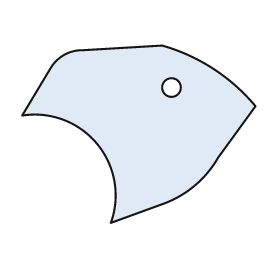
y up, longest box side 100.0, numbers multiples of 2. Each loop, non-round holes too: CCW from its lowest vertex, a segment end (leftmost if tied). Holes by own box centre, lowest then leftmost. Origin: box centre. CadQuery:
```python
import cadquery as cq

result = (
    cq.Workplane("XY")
    .moveTo(-12.0, -38.0)
    .lineTo(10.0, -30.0)
    .threePointArc((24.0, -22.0), (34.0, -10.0))
    .lineTo(50.0, 12.0)
    .threePointArc((32.0, 28.0), (10.0, 38.0))
    .lineTo(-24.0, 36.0)
    .threePointArc((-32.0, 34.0), (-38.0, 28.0))
    .lineTo(-50.0, 8.0)
    .threePointArc((-18.0, -4.0), (-12.0, -38.0))
    .close()
    .moveTo(14.0, 20.0)
    .circle(4.0)
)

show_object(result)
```